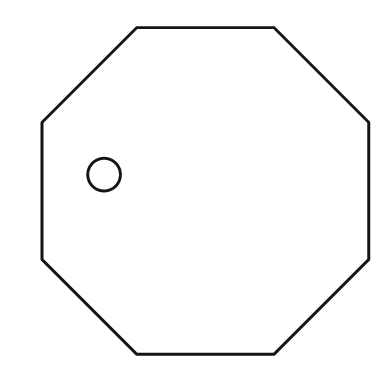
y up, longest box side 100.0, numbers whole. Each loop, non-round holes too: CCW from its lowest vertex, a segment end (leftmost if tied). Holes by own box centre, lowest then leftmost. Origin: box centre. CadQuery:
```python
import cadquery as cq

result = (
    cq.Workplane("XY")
    .moveTo(-21.0, -50.0)
    .lineTo(21.0, -50.0)
    .lineTo(50.0, -21.0)
    .lineTo(50.0, 21.0)
    .lineTo(21.0, 50.0)
    .lineTo(-21.0, 50.0)
    .lineTo(-50.0, 21.0)
    .lineTo(-50.0, -21.0)
    .close()
    .moveTo(-31.0, 5.0)
    .circle(5.0)
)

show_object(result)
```